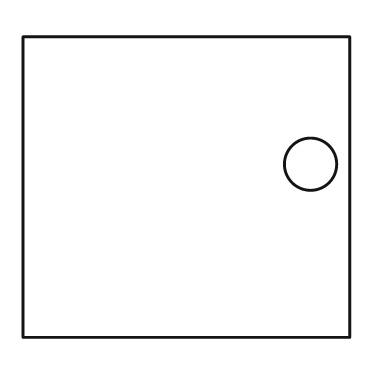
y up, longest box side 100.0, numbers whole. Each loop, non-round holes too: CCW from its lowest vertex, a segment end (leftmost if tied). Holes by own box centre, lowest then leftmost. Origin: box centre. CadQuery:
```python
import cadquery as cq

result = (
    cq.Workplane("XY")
    .moveTo(-50.0, -46.0)
    .lineTo(50.0, -46.0)
    .lineTo(50.0, 46.0)
    .lineTo(-50.0, 46.0)
    .close()
    .moveTo(38.0, 7.0)
    .circle(8.0)
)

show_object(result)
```